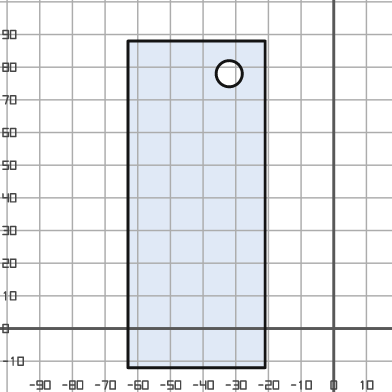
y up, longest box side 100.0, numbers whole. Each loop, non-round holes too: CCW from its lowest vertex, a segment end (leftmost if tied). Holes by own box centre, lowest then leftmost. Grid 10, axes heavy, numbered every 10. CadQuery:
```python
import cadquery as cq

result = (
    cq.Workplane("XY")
    .moveTo(-63.0, -12.0)
    .lineTo(-21.0, -12.0)
    .lineTo(-21.0, 88.0)
    .lineTo(-63.0, 88.0)
    .close()
    .moveTo(-32.0, 78.0)
    .circle(4.0)
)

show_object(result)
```